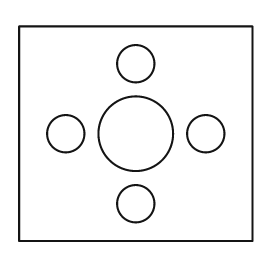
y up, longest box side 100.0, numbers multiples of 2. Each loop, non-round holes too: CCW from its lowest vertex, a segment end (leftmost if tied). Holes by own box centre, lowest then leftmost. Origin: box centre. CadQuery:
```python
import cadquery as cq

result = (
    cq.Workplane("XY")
    .moveTo(-50.0, -46.0)
    .lineTo(50.0, -46.0)
    .lineTo(50.0, 46.0)
    .lineTo(-50.0, 46.0)
    .close()
    .moveTo(0.0, -30.0)
    .circle(8.0)
    .moveTo(-30.0, 0.0)
    .circle(8.0)
    .moveTo(0.0, 0.0)
    .circle(16.0)
    .moveTo(30.0, 0.0)
    .circle(8.0)
    .moveTo(0.0, 30.0)
    .circle(8.0)
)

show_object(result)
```